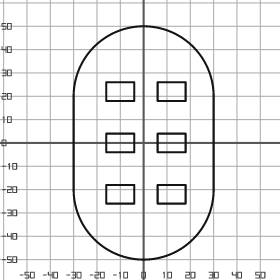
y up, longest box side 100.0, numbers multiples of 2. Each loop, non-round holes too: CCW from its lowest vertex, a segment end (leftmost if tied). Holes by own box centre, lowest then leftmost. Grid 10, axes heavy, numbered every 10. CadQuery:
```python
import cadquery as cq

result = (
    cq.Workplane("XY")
    .moveTo(-30.0, -20.0)
    .threePointArc((0.0, -50.0), (30.0, -20.0))
    .lineTo(30.0, 20.0)
    .threePointArc((0.0, 50.0), (-30.0, 20.0))
    .close()
    .moveTo(-16.0, -26.0)
    .lineTo(-4.0, -26.0)
    .lineTo(-4.0, -18.0)
    .lineTo(-16.0, -18.0)
    .close()
    .moveTo(6.0, -26.0)
    .lineTo(18.0, -26.0)
    .lineTo(18.0, -18.0)
    .lineTo(6.0, -18.0)
    .close()
    .moveTo(-16.0, -4.0)
    .lineTo(-4.0, -4.0)
    .lineTo(-4.0, 4.0)
    .lineTo(-16.0, 4.0)
    .close()
    .moveTo(6.0, -4.0)
    .lineTo(18.0, -4.0)
    .lineTo(18.0, 4.0)
    .lineTo(6.0, 4.0)
    .close()
    .moveTo(-16.0, 18.0)
    .lineTo(-4.0, 18.0)
    .lineTo(-4.0, 26.0)
    .lineTo(-16.0, 26.0)
    .close()
    .moveTo(6.0, 18.0)
    .lineTo(18.0, 18.0)
    .lineTo(18.0, 26.0)
    .lineTo(6.0, 26.0)
    .close()
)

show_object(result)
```